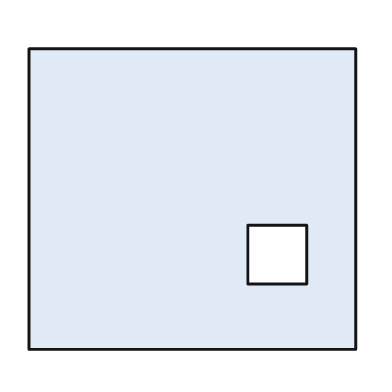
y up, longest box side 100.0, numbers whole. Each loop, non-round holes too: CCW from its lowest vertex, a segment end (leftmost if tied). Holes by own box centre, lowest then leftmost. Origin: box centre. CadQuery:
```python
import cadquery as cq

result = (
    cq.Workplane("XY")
    .moveTo(-50.0, -46.0)
    .lineTo(50.0, -46.0)
    .lineTo(50.0, 46.0)
    .lineTo(-50.0, 46.0)
    .close()
    .moveTo(17.0, -26.0)
    .lineTo(35.0, -26.0)
    .lineTo(35.0, -8.0)
    .lineTo(17.0, -8.0)
    .close()
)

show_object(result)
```